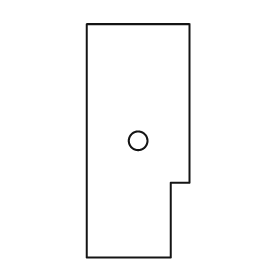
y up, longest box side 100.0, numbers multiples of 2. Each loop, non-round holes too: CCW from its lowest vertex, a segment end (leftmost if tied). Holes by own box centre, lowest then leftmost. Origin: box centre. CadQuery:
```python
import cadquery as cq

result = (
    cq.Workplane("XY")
    .moveTo(-22.0, -50.0)
    .lineTo(14.0, -50.0)
    .lineTo(14.0, -18.0)
    .lineTo(22.0, -18.0)
    .lineTo(22.0, 50.0)
    .lineTo(-22.0, 50.0)
    .close()
    .moveTo(0.0, 0.0)
    .circle(4.0)
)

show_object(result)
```